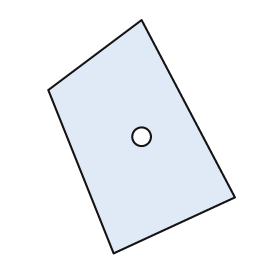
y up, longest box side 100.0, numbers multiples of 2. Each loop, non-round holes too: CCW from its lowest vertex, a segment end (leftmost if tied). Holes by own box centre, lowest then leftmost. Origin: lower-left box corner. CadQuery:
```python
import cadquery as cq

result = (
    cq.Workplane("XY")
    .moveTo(28.0, 0.0)
    .lineTo(80.0, 24.0)
    .lineTo(40.0, 100.0)
    .lineTo(0.0, 70.0)
    .close()
    .moveTo(40.0, 50.0)
    .circle(4.0)
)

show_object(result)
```